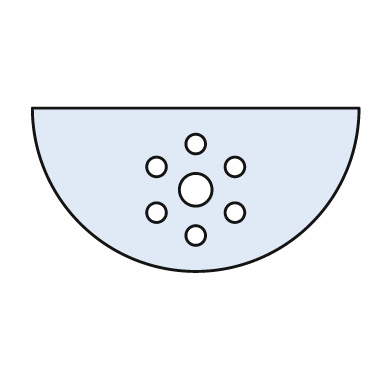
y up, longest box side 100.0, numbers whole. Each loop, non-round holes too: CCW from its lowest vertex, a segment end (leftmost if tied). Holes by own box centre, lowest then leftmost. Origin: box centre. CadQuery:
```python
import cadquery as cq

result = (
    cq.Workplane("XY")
    .moveTo(-50.0, 25.0)
    .threePointArc((0.0, -25.0), (50.0, 25.0))
    .close()
    .moveTo(0.0, -14.0)
    .circle(3.0)
    .moveTo(-12.0, -7.0)
    .circle(3.0)
    .moveTo(12.0, -7.0)
    .circle(3.0)
    .moveTo(0.0, 0.0)
    .circle(5.0)
    .moveTo(-12.0, 7.0)
    .circle(3.0)
    .moveTo(12.0, 7.0)
    .circle(3.0)
    .moveTo(0.0, 14.0)
    .circle(3.0)
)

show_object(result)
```